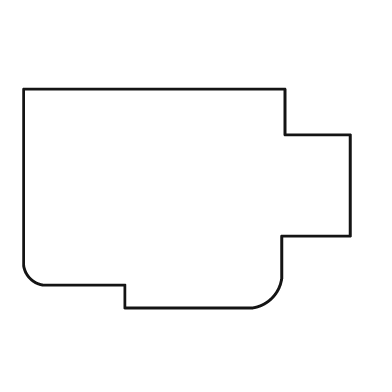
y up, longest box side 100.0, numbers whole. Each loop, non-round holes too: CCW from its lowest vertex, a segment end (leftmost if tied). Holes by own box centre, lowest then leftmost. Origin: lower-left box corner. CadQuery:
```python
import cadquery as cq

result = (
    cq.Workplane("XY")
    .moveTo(31.0, 0.0)
    .lineTo(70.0, 0.0)
    .threePointArc((76.0, 3.0), (79.0, 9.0))
    .lineTo(79.0, 22.0)
    .lineTo(100.0, 22.0)
    .lineTo(100.0, 53.0)
    .lineTo(80.0, 53.0)
    .lineTo(80.0, 67.0)
    .lineTo(0.0, 67.0)
    .lineTo(0.0, 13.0)
    .threePointArc((2.0, 9.0), (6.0, 7.0))
    .lineTo(31.0, 7.0)
    .close()
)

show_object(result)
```